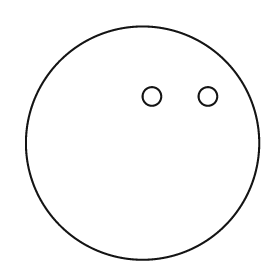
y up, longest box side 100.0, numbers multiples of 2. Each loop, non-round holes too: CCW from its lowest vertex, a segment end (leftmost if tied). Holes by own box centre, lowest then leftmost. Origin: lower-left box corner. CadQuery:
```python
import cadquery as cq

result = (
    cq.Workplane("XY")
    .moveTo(50.0, 50.0)
    .circle(50.0)
    .moveTo(54.0, 70.0)
    .circle(4.0)
    .moveTo(78.0, 70.0)
    .circle(4.0)
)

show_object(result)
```